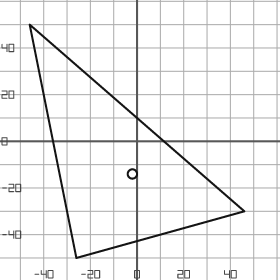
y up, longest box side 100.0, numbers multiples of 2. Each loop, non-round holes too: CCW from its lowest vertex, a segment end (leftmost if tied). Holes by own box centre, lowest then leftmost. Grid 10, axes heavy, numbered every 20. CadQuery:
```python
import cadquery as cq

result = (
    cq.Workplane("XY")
    .moveTo(-26.0, -50.0)
    .lineTo(46.0, -30.0)
    .lineTo(-46.0, 50.0)
    .close()
    .moveTo(-2.0, -14.0)
    .circle(2.0)
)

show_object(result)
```